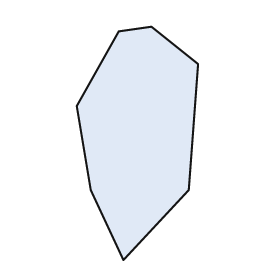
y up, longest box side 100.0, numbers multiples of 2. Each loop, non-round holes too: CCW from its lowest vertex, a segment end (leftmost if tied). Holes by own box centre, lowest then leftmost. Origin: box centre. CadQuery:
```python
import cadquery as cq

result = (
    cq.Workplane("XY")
    .moveTo(-6.0, -50.0)
    .lineTo(22.0, -20.0)
    .lineTo(26.0, 34.0)
    .lineTo(6.0, 50.0)
    .lineTo(-8.0, 48.0)
    .lineTo(-26.0, 16.0)
    .lineTo(-20.0, -20.0)
    .close()
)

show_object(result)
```